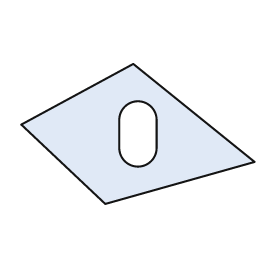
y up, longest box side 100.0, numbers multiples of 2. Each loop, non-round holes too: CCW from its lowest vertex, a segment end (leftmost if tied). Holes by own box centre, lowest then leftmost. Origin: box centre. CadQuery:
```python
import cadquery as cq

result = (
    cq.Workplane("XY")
    .moveTo(-14.0, -30.0)
    .lineTo(50.0, -12.0)
    .lineTo(-2.0, 30.0)
    .lineTo(-50.0, 4.0)
    .close()
    .moveTo(-8.0, -6.0)
    .threePointArc((0.0, -14.0), (8.0, -6.0))
    .lineTo(8.0, 6.0)
    .threePointArc((0.0, 14.0), (-8.0, 6.0))
    .close()
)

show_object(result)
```